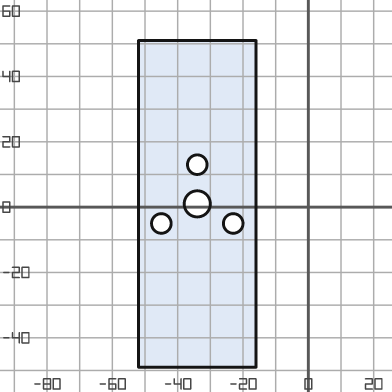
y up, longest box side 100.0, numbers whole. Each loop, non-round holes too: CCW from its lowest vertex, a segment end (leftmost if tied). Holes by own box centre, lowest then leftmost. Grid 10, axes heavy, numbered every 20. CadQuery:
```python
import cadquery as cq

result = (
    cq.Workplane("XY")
    .moveTo(-52.0, -49.0)
    .lineTo(-16.0, -49.0)
    .lineTo(-16.0, 51.0)
    .lineTo(-52.0, 51.0)
    .close()
    .moveTo(-45.0, -5.0)
    .circle(3.0)
    .moveTo(-23.0, -5.0)
    .circle(3.0)
    .moveTo(-34.0, 1.0)
    .circle(4.0)
    .moveTo(-34.0, 13.0)
    .circle(3.0)
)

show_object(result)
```